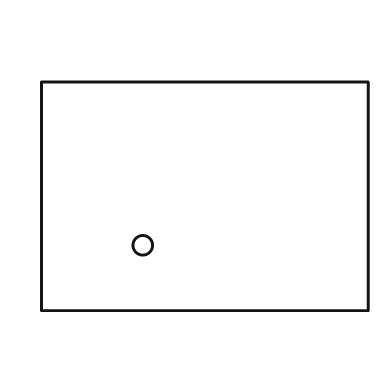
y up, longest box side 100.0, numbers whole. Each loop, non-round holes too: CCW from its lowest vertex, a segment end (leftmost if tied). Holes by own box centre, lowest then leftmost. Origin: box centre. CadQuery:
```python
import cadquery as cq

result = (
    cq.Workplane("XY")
    .moveTo(-50.0, -35.0)
    .lineTo(50.0, -35.0)
    .lineTo(50.0, 35.0)
    .lineTo(-50.0, 35.0)
    .close()
    .moveTo(-19.0, -15.0)
    .circle(3.0)
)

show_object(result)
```